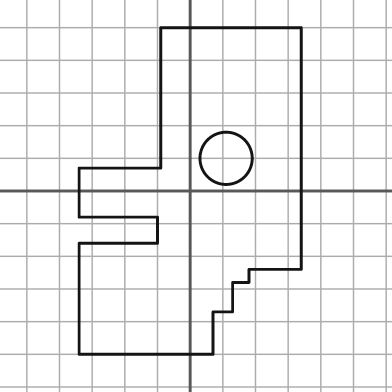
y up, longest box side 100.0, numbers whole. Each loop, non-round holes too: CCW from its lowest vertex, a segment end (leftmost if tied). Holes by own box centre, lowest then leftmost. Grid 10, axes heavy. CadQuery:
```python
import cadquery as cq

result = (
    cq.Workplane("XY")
    .moveTo(-34.0, -50.0)
    .lineTo(7.0, -50.0)
    .lineTo(7.0, -37.0)
    .lineTo(13.0, -37.0)
    .lineTo(13.0, -28.0)
    .lineTo(18.0, -28.0)
    .lineTo(18.0, -24.0)
    .lineTo(34.0, -24.0)
    .lineTo(34.0, 50.0)
    .lineTo(-9.0, 50.0)
    .lineTo(-9.0, 7.0)
    .lineTo(-34.0, 7.0)
    .lineTo(-34.0, -8.0)
    .lineTo(-10.0, -8.0)
    .lineTo(-10.0, -16.0)
    .lineTo(-34.0, -16.0)
    .close()
    .moveTo(11.0, 10.0)
    .circle(8.0)
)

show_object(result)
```